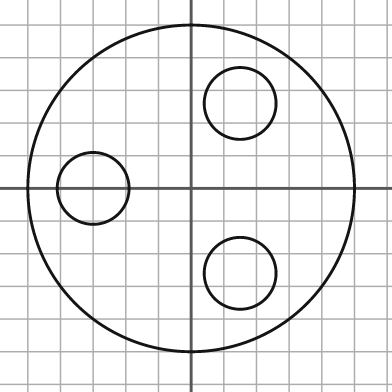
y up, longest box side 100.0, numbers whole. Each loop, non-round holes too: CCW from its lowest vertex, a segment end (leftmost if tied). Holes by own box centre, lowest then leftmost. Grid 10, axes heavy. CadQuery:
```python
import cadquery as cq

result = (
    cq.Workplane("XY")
    .moveTo(0.0, 0.0)
    .circle(50.0)
    .moveTo(15.0, -26.0)
    .circle(11.0)
    .moveTo(-30.0, 0.0)
    .circle(11.0)
    .moveTo(15.0, 26.0)
    .circle(11.0)
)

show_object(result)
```